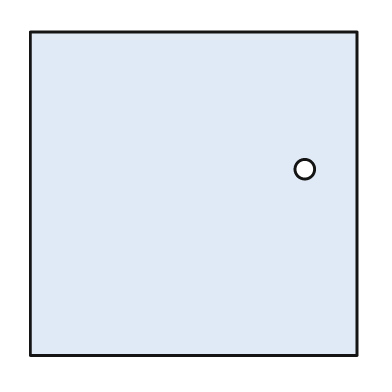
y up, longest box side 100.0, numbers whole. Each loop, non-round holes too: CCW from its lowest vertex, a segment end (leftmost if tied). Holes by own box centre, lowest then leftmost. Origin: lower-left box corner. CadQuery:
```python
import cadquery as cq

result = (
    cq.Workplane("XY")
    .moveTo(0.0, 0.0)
    .lineTo(100.0, 0.0)
    .lineTo(100.0, 99.0)
    .lineTo(0.0, 99.0)
    .close()
    .moveTo(84.0, 57.0)
    .circle(3.0)
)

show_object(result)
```